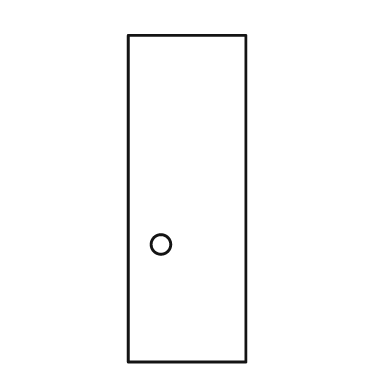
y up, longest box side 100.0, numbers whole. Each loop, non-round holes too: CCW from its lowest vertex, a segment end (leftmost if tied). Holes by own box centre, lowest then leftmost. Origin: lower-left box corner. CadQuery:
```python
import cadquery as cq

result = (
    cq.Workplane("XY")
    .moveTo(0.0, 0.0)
    .lineTo(36.0, 0.0)
    .lineTo(36.0, 100.0)
    .lineTo(0.0, 100.0)
    .close()
    .moveTo(10.0, 36.0)
    .circle(3.0)
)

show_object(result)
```